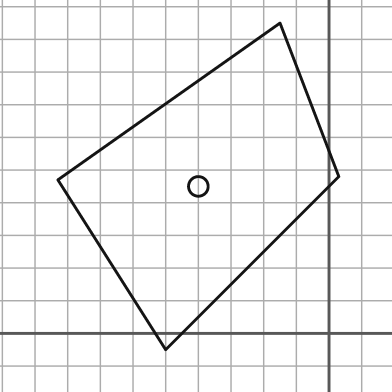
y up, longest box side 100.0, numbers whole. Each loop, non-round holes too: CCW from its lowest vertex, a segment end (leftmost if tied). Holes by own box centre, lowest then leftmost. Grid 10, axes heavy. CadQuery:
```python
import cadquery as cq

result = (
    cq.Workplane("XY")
    .moveTo(-50.0, -5.0)
    .lineTo(3.0, 48.0)
    .lineTo(-15.0, 95.0)
    .lineTo(-83.0, 47.0)
    .close()
    .moveTo(-40.0, 45.0)
    .circle(3.0)
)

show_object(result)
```